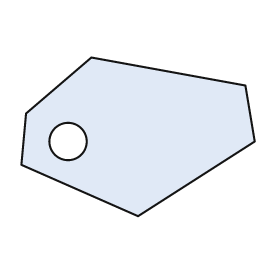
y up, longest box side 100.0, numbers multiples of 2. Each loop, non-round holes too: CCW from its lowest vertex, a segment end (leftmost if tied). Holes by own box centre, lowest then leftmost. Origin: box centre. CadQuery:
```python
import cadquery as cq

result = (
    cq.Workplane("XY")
    .moveTo(0.0, -34.0)
    .lineTo(50.0, -2.0)
    .lineTo(46.0, 22.0)
    .lineTo(-20.0, 34.0)
    .lineTo(-48.0, 10.0)
    .lineTo(-50.0, -12.0)
    .close()
    .moveTo(-30.0, -2.0)
    .circle(8.0)
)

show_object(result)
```